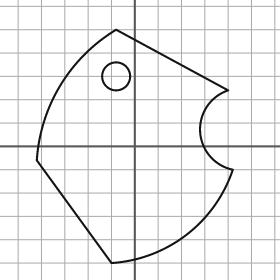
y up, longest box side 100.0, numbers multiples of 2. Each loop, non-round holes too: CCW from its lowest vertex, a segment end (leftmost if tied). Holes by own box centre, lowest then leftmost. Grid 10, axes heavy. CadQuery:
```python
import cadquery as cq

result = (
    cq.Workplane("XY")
    .moveTo(-10.0, -50.0)
    .threePointArc((22.0, -38.0), (42.0, -10.0))
    .threePointArc((28.0, 6.0), (40.0, 24.0))
    .lineTo(-8.0, 50.0)
    .threePointArc((-32.0, 26.0), (-42.0, -6.0))
    .close()
    .moveTo(-8.0, 30.0)
    .circle(6.0)
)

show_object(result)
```